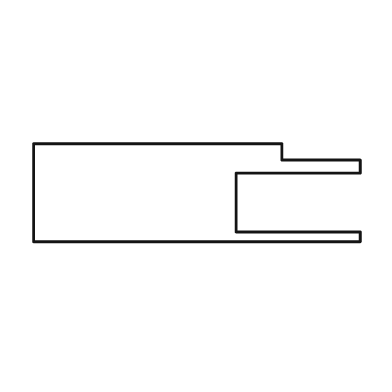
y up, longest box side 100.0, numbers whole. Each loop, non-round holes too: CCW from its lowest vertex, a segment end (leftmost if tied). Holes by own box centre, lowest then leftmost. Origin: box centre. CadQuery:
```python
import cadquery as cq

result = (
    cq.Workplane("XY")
    .moveTo(-50.0, -15.0)
    .lineTo(50.0, -15.0)
    .lineTo(50.0, -12.0)
    .lineTo(12.0, -12.0)
    .lineTo(12.0, 6.0)
    .lineTo(50.0, 6.0)
    .lineTo(50.0, 10.0)
    .lineTo(26.0, 10.0)
    .lineTo(26.0, 15.0)
    .lineTo(-50.0, 15.0)
    .close()
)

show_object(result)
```